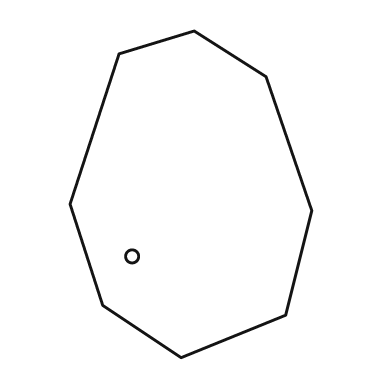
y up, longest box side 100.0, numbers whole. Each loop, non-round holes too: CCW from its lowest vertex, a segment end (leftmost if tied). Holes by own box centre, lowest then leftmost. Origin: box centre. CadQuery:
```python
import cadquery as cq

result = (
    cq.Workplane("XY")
    .moveTo(-3.0, -50.0)
    .lineTo(29.0, -37.0)
    .lineTo(37.0, -5.0)
    .lineTo(23.0, 36.0)
    .lineTo(1.0, 50.0)
    .lineTo(-22.0, 43.0)
    .lineTo(-37.0, -3.0)
    .lineTo(-27.0, -34.0)
    .close()
    .moveTo(-18.0, -19.0)
    .circle(2.0)
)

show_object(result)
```